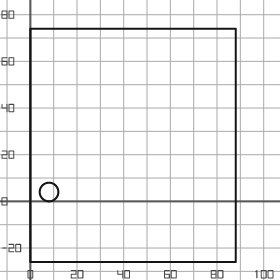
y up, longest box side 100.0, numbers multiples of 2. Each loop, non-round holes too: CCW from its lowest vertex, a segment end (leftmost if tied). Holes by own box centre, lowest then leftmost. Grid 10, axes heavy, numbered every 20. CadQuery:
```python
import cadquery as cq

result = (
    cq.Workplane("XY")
    .moveTo(0.0, -26.0)
    .lineTo(88.0, -26.0)
    .lineTo(88.0, 74.0)
    .lineTo(0.0, 74.0)
    .close()
    .moveTo(8.0, 4.0)
    .circle(4.0)
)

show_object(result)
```